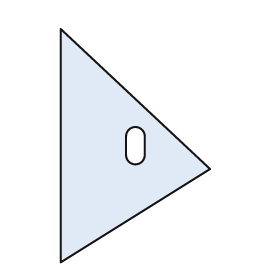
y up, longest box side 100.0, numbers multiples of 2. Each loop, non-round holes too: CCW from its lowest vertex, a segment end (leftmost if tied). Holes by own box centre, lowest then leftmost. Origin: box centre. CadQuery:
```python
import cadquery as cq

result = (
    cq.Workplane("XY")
    .moveTo(-32.0, -50.0)
    .lineTo(32.0, -10.0)
    .lineTo(-32.0, 50.0)
    .close()
    .moveTo(-4.0, -4.0)
    .threePointArc((0.0, -8.0), (4.0, -4.0))
    .lineTo(4.0, 4.0)
    .threePointArc((0.0, 8.0), (-4.0, 4.0))
    .close()
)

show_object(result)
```